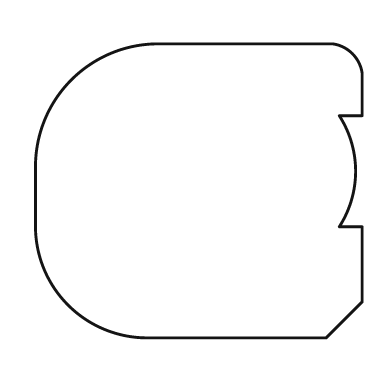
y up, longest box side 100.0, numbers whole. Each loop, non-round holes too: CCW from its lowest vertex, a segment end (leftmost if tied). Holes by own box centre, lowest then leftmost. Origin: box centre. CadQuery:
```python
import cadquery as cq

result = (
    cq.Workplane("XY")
    .moveTo(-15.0, -45.0)
    .lineTo(39.0, -45.0)
    .lineTo(50.0, -34.0)
    .lineTo(50.0, -11.0)
    .lineTo(43.0, -11.0)
    .threePointArc((48.0, 6.0), (43.0, 23.0))
    .lineTo(50.0, 23.0)
    .lineTo(50.0, 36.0)
    .threePointArc((47.0, 42.0), (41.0, 45.0))
    .lineTo(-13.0, 45.0)
    .threePointArc((-39.0, 34.0), (-50.0, 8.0))
    .lineTo(-50.0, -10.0)
    .threePointArc((-40.0, -35.0), (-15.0, -45.0))
    .close()
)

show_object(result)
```